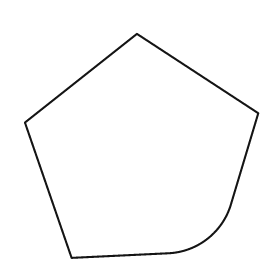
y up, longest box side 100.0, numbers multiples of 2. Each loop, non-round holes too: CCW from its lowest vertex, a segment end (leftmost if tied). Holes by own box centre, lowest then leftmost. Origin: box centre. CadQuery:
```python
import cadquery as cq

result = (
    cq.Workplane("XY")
    .moveTo(-30.0, -48.0)
    .lineTo(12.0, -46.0)
    .threePointArc((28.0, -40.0), (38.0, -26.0))
    .lineTo(50.0, 14.0)
    .lineTo(-2.0, 48.0)
    .lineTo(-50.0, 10.0)
    .close()
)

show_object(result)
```